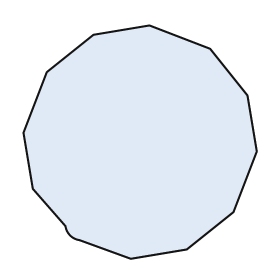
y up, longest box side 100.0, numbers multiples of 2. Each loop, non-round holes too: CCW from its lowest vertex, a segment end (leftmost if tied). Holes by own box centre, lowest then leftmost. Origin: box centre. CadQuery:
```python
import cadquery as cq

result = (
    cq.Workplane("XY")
    .moveTo(-4.0, -50.0)
    .lineTo(20.0, -46.0)
    .lineTo(40.0, -30.0)
    .lineTo(50.0, -4.0)
    .lineTo(46.0, 20.0)
    .lineTo(30.0, 40.0)
    .lineTo(4.0, 50.0)
    .lineTo(-20.0, 46.0)
    .lineTo(-40.0, 30.0)
    .lineTo(-50.0, 4.0)
    .lineTo(-46.0, -20.0)
    .lineTo(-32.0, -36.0)
    .threePointArc((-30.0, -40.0), (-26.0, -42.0))
    .close()
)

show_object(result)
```